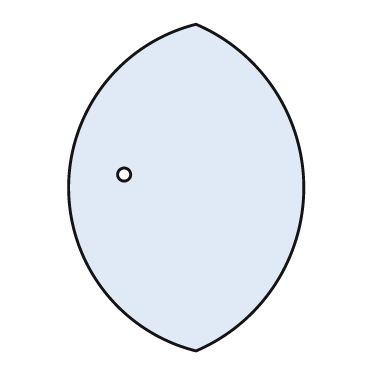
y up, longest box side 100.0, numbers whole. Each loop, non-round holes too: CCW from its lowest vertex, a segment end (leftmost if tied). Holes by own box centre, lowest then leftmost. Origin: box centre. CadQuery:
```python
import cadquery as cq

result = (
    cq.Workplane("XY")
    .moveTo(3.0, -50.0)
    .threePointArc((36.0, 0.0), (3.0, 50.0))
    .threePointArc((-36.0, 0.0), (3.0, -50.0))
    .close()
    .moveTo(-19.0, 4.0)
    .circle(2.0)
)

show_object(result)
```